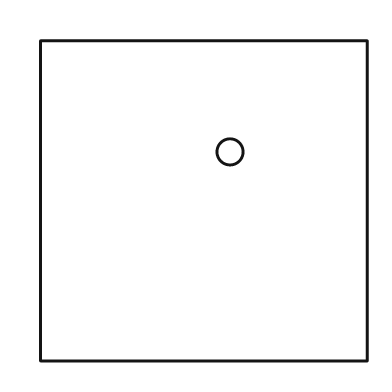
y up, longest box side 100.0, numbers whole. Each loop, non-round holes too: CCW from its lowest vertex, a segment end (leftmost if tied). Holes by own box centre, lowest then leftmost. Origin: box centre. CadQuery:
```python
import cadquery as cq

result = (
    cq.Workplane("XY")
    .moveTo(-50.0, -49.0)
    .lineTo(50.0, -49.0)
    .lineTo(50.0, 49.0)
    .lineTo(-50.0, 49.0)
    .close()
    .moveTo(8.0, 15.0)
    .circle(4.0)
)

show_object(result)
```